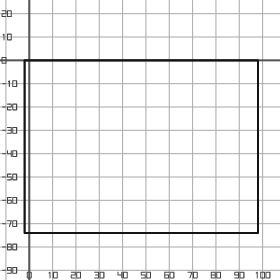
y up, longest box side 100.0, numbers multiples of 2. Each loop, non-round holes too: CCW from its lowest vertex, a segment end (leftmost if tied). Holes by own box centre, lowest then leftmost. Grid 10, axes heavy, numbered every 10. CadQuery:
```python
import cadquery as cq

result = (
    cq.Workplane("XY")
    .moveTo(-2.0, -74.0)
    .lineTo(98.0, -74.0)
    .lineTo(98.0, 0.0)
    .lineTo(-2.0, 0.0)
    .close()
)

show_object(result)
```